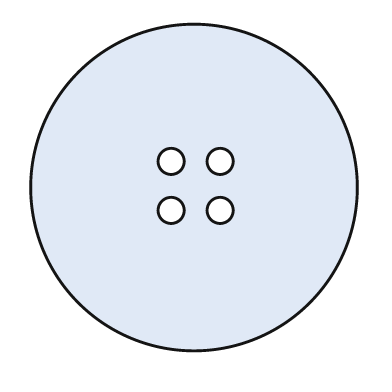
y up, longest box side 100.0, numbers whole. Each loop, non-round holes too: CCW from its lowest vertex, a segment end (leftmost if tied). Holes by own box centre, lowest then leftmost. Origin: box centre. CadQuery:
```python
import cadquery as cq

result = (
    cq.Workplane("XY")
    .moveTo(0.0, 0.0)
    .circle(50.0)
    .moveTo(-7.0, -7.0)
    .circle(4.0)
    .moveTo(8.0, -7.0)
    .circle(4.0)
    .moveTo(-7.0, 8.0)
    .circle(4.0)
    .moveTo(8.0, 8.0)
    .circle(4.0)
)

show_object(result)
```